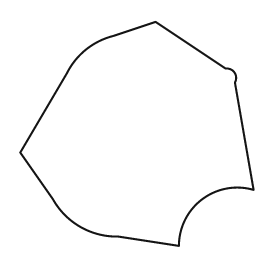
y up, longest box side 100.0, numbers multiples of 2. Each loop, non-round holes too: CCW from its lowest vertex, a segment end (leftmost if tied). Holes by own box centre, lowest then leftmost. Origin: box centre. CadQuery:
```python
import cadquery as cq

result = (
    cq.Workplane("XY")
    .moveTo(18.0, -48.0)
    .threePointArc((28.0, -28.0), (50.0, -24.0))
    .lineTo(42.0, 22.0)
    .threePointArc((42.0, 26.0), (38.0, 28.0))
    .lineTo(8.0, 48.0)
    .lineTo(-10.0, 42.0)
    .threePointArc((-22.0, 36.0), (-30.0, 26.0))
    .lineTo(-50.0, -8.0)
    .lineTo(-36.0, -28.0)
    .threePointArc((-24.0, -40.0), (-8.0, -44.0))
    .close()
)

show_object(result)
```